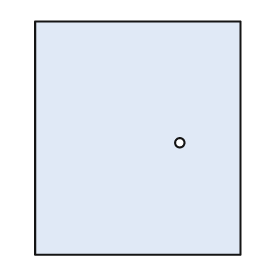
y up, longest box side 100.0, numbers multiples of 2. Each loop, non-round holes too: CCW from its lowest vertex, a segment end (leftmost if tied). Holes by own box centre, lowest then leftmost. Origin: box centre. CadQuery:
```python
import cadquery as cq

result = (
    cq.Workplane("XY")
    .moveTo(-44.0, -50.0)
    .lineTo(44.0, -50.0)
    .lineTo(44.0, 50.0)
    .lineTo(-44.0, 50.0)
    .close()
    .moveTo(18.0, -2.0)
    .circle(2.0)
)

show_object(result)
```